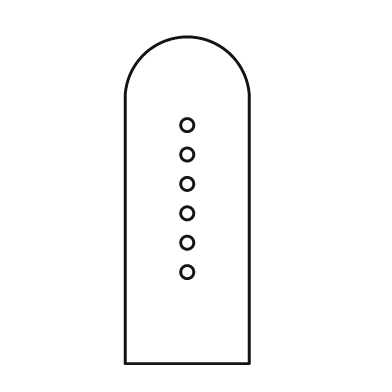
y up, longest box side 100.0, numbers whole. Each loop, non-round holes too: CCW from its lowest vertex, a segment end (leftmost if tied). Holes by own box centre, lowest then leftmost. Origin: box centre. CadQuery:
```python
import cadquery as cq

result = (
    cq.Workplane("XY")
    .moveTo(-19.0, -50.0)
    .lineTo(19.0, -50.0)
    .lineTo(19.0, 32.0)
    .threePointArc((0.0, 50.0), (-19.0, 32.0))
    .close()
    .moveTo(0.0, -22.0)
    .circle(2.0)
    .moveTo(0.0, -13.0)
    .circle(2.0)
    .moveTo(0.0, -4.0)
    .circle(2.0)
    .moveTo(0.0, 5.0)
    .circle(2.0)
    .moveTo(0.0, 14.0)
    .circle(2.0)
    .moveTo(0.0, 23.0)
    .circle(2.0)
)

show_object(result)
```